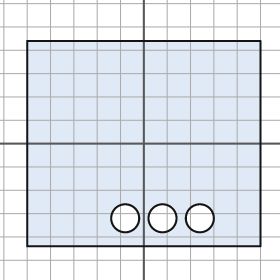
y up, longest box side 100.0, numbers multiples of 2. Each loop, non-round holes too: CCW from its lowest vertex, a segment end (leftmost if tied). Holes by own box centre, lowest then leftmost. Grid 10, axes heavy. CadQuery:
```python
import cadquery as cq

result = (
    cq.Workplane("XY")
    .moveTo(-50.0, -44.0)
    .lineTo(50.0, -44.0)
    .lineTo(50.0, 44.0)
    .lineTo(-50.0, 44.0)
    .close()
    .moveTo(-8.0, -32.0)
    .circle(6.0)
    .moveTo(8.0, -32.0)
    .circle(6.0)
    .moveTo(24.0, -32.0)
    .circle(6.0)
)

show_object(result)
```